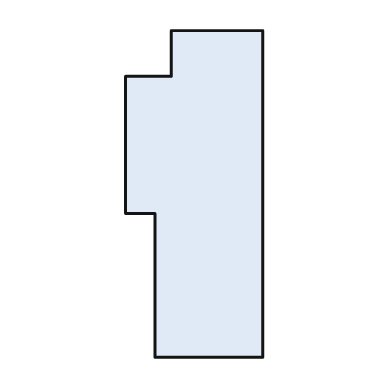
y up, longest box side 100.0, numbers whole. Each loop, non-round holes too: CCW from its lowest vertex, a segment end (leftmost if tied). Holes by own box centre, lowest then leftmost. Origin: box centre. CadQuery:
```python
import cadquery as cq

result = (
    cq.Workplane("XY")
    .moveTo(-12.0, -50.0)
    .lineTo(21.0, -50.0)
    .lineTo(21.0, 50.0)
    .lineTo(-7.0, 50.0)
    .lineTo(-7.0, 36.0)
    .lineTo(-21.0, 36.0)
    .lineTo(-21.0, -6.0)
    .lineTo(-12.0, -6.0)
    .close()
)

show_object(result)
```